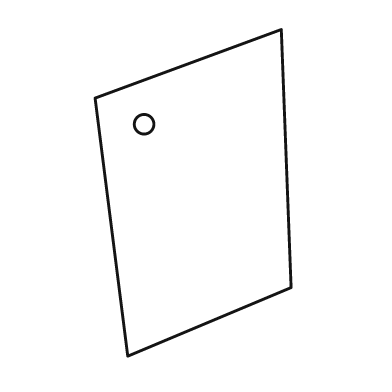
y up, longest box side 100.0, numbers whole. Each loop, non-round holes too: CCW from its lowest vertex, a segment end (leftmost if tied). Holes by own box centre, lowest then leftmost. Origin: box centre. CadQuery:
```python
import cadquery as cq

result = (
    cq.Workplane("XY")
    .moveTo(-20.0, -50.0)
    .lineTo(30.0, -29.0)
    .lineTo(27.0, 50.0)
    .lineTo(-30.0, 29.0)
    .close()
    .moveTo(-15.0, 21.0)
    .circle(3.0)
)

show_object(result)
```